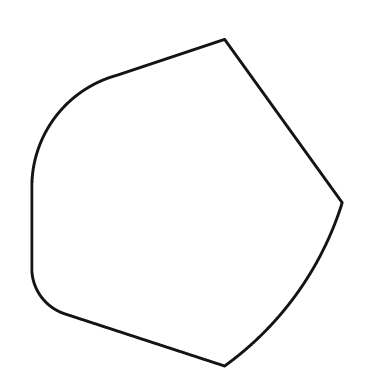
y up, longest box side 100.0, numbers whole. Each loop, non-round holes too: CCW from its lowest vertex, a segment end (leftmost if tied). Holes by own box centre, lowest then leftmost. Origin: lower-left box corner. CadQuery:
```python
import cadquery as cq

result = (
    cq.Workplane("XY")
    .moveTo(59.0, 0.0)
    .threePointArc((81.0, 22.0), (95.0, 50.0))
    .lineTo(59.0, 100.0)
    .lineTo(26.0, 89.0)
    .threePointArc((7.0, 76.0), (0.0, 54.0))
    .lineTo(0.0, 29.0)
    .threePointArc((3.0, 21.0), (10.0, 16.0))
    .close()
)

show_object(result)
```